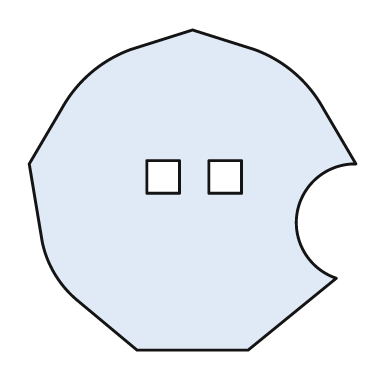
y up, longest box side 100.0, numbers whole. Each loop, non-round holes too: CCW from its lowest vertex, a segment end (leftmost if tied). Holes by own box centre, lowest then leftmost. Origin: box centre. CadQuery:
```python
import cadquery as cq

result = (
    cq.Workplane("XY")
    .moveTo(-17.0, -49.0)
    .lineTo(17.0, -49.0)
    .lineTo(44.0, -27.0)
    .threePointArc((32.0, -7.0), (50.0, 8.0))
    .lineTo(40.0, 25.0)
    .threePointArc((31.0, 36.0), (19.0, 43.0))
    .lineTo(0.0, 49.0)
    .lineTo(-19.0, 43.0)
    .threePointArc((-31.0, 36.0), (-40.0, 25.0))
    .lineTo(-50.0, 8.0)
    .lineTo(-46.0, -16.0)
    .threePointArc((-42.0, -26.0), (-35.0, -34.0))
    .close()
    .moveTo(-14.0, -1.0)
    .lineTo(-4.0, -1.0)
    .lineTo(-4.0, 9.0)
    .lineTo(-14.0, 9.0)
    .close()
    .moveTo(5.0, -1.0)
    .lineTo(15.0, -1.0)
    .lineTo(15.0, 9.0)
    .lineTo(5.0, 9.0)
    .close()
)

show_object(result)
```